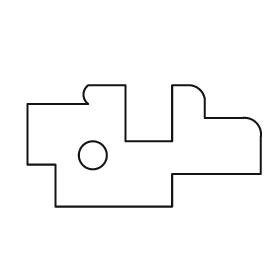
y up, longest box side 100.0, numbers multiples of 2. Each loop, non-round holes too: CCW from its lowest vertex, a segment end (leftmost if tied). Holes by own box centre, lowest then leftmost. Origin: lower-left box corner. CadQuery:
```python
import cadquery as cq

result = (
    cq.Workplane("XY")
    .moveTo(12.0, 0.0)
    .lineTo(62.0, 0.0)
    .lineTo(62.0, 14.0)
    .lineTo(100.0, 14.0)
    .lineTo(100.0, 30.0)
    .threePointArc((98.0, 36.0), (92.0, 38.0))
    .lineTo(76.0, 38.0)
    .lineTo(76.0, 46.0)
    .threePointArc((74.0, 50.0), (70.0, 52.0))
    .lineTo(62.0, 52.0)
    .lineTo(62.0, 28.0)
    .lineTo(42.0, 28.0)
    .lineTo(42.0, 52.0)
    .lineTo(26.0, 52.0)
    .threePointArc((24.0, 48.0), (26.0, 44.0))
    .lineTo(0.0, 44.0)
    .lineTo(0.0, 18.0)
    .lineTo(12.0, 18.0)
    .close()
    .moveTo(28.0, 22.0)
    .circle(6.0)
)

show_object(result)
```